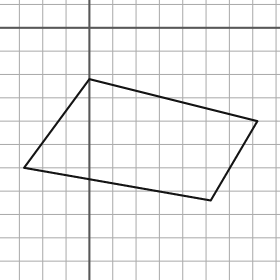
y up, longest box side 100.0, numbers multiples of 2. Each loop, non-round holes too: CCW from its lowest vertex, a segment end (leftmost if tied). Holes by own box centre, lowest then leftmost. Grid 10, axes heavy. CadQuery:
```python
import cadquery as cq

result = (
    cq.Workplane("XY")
    .moveTo(52.0, -74.0)
    .lineTo(72.0, -40.0)
    .lineTo(0.0, -22.0)
    .lineTo(-28.0, -60.0)
    .close()
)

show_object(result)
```